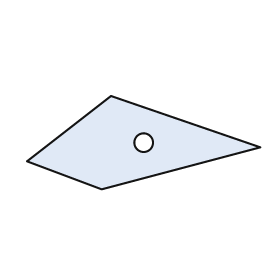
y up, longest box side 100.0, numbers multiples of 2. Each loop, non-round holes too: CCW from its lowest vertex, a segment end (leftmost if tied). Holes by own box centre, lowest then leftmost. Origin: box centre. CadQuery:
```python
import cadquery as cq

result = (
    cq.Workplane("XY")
    .moveTo(-18.0, -20.0)
    .lineTo(50.0, -2.0)
    .lineTo(-14.0, 20.0)
    .lineTo(-50.0, -8.0)
    .close()
    .moveTo(0.0, 0.0)
    .circle(4.0)
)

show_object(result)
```